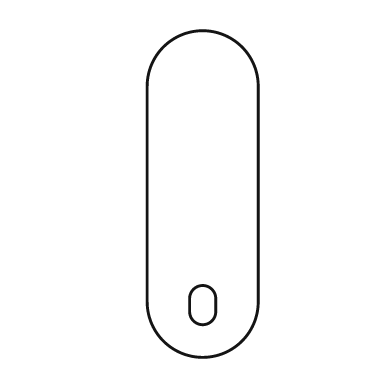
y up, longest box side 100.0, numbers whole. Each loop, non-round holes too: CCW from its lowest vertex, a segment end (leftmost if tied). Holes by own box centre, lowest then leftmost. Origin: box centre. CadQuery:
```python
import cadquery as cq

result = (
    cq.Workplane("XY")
    .moveTo(-17.0, -33.0)
    .threePointArc((0.0, -50.0), (17.0, -33.0))
    .lineTo(17.0, 33.0)
    .threePointArc((0.0, 50.0), (-17.0, 33.0))
    .close()
    .moveTo(-4.0, -36.0)
    .threePointArc((0.0, -40.0), (4.0, -36.0))
    .lineTo(4.0, -32.0)
    .threePointArc((0.0, -28.0), (-4.0, -32.0))
    .close()
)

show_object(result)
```